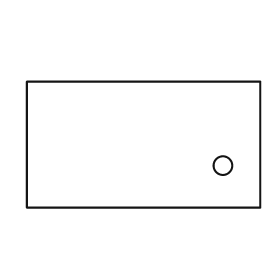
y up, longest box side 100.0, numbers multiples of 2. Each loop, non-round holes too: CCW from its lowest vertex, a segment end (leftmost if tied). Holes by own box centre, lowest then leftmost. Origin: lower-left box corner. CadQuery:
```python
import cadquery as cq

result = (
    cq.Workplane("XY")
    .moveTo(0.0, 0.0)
    .lineTo(100.0, 0.0)
    .lineTo(100.0, 54.0)
    .lineTo(0.0, 54.0)
    .close()
    .moveTo(84.0, 18.0)
    .circle(4.0)
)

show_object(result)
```